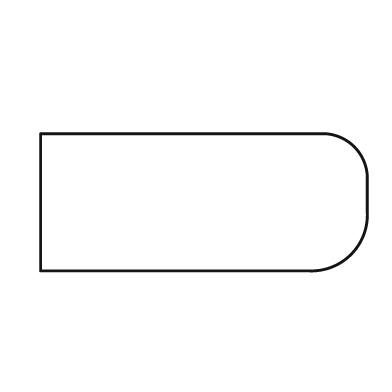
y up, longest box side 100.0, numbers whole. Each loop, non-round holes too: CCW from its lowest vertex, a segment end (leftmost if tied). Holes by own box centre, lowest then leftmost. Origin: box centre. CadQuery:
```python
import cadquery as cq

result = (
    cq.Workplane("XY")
    .moveTo(-50.0, -21.0)
    .lineTo(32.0, -21.0)
    .threePointArc((45.0, -16.0), (50.0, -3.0))
    .lineTo(50.0, 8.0)
    .threePointArc((46.0, 17.0), (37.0, 21.0))
    .lineTo(-50.0, 21.0)
    .close()
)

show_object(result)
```